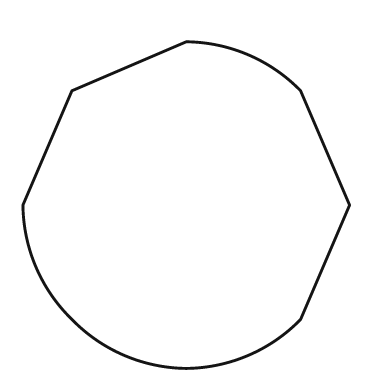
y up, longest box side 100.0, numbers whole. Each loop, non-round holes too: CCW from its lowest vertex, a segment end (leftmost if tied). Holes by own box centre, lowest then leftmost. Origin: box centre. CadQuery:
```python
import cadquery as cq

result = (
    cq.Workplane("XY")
    .moveTo(0.0, -50.0)
    .threePointArc((19.0, -46.0), (35.0, -35.0))
    .lineTo(50.0, 0.0)
    .lineTo(35.0, 35.0)
    .threePointArc((19.0, 46.0), (0.0, 50.0))
    .lineTo(-35.0, 35.0)
    .lineTo(-50.0, 0.0)
    .threePointArc((-46.0, -19.0), (-35.0, -35.0))
    .threePointArc((-19.0, -46.0), (0.0, -50.0))
    .close()
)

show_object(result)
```